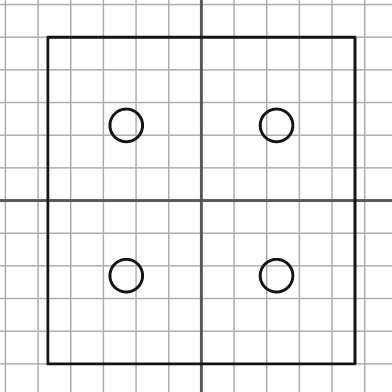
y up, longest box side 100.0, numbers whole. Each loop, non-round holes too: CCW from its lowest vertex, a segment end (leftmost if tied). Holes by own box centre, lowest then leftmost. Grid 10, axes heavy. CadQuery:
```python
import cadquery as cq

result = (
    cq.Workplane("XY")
    .moveTo(-47.0, -50.0)
    .lineTo(47.0, -50.0)
    .lineTo(47.0, 50.0)
    .lineTo(-47.0, 50.0)
    .close()
    .moveTo(-23.0, -23.0)
    .circle(5.0)
    .moveTo(23.0, -23.0)
    .circle(5.0)
    .moveTo(-23.0, 23.0)
    .circle(5.0)
    .moveTo(23.0, 23.0)
    .circle(5.0)
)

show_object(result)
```